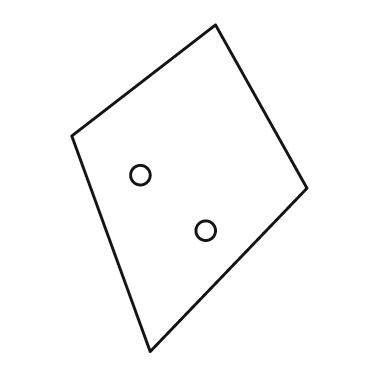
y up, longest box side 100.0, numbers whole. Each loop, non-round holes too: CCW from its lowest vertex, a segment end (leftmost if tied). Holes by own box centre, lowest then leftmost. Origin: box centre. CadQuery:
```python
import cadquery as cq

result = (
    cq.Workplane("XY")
    .moveTo(-12.0, -50.0)
    .lineTo(36.0, 0.0)
    .lineTo(8.0, 50.0)
    .lineTo(-36.0, 16.0)
    .close()
    .moveTo(5.0, -13.0)
    .circle(3.0)
    .moveTo(-15.0, 4.0)
    .circle(3.0)
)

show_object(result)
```